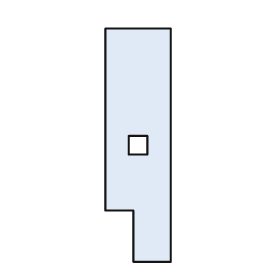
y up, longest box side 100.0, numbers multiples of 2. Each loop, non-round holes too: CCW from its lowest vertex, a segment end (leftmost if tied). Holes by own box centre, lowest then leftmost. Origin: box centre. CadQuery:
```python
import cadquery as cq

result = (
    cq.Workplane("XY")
    .moveTo(-2.0, -50.0)
    .lineTo(14.0, -50.0)
    .lineTo(14.0, 50.0)
    .lineTo(-14.0, 50.0)
    .lineTo(-14.0, -28.0)
    .lineTo(-2.0, -28.0)
    .close()
    .moveTo(-4.0, -4.0)
    .lineTo(4.0, -4.0)
    .lineTo(4.0, 4.0)
    .lineTo(-4.0, 4.0)
    .close()
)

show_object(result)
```